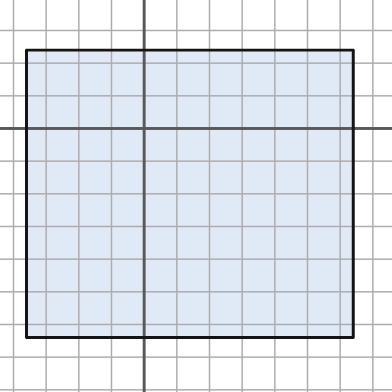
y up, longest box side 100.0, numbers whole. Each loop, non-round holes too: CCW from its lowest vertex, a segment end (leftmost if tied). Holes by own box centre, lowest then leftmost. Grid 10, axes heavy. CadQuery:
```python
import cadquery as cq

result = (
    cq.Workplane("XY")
    .moveTo(-36.0, -64.0)
    .lineTo(64.0, -64.0)
    .lineTo(64.0, 24.0)
    .lineTo(-36.0, 24.0)
    .close()
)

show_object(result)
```